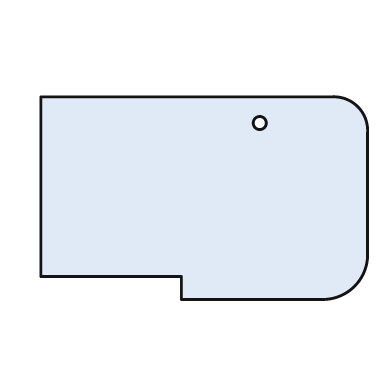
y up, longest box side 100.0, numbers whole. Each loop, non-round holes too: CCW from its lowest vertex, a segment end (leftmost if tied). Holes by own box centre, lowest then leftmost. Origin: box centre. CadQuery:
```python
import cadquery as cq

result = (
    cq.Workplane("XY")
    .moveTo(-7.0, -31.0)
    .lineTo(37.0, -31.0)
    .threePointArc((46.0, -27.0), (50.0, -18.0))
    .lineTo(50.0, 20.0)
    .threePointArc((47.0, 28.0), (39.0, 31.0))
    .lineTo(-50.0, 31.0)
    .lineTo(-50.0, -24.0)
    .lineTo(-7.0, -24.0)
    .close()
    .moveTo(17.0, 23.0)
    .circle(2.0)
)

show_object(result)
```